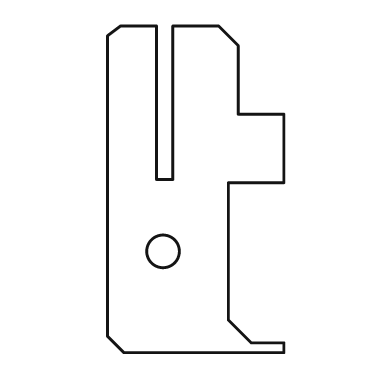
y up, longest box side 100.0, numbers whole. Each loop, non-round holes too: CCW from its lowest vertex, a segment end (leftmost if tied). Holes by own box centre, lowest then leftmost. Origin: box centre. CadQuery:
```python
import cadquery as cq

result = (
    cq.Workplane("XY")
    .moveTo(-22.0, -50.0)
    .lineTo(27.0, -50.0)
    .lineTo(27.0, -47.0)
    .lineTo(17.0, -47.0)
    .lineTo(10.0, -40.0)
    .lineTo(10.0, 2.0)
    .lineTo(27.0, 2.0)
    .lineTo(27.0, 23.0)
    .lineTo(13.0, 23.0)
    .lineTo(13.0, 44.0)
    .lineTo(7.0, 50.0)
    .lineTo(-7.0, 50.0)
    .lineTo(-7.0, 3.0)
    .lineTo(-12.0, 3.0)
    .lineTo(-12.0, 50.0)
    .lineTo(-23.0, 50.0)
    .lineTo(-27.0, 47.0)
    .lineTo(-27.0, -45.0)
    .close()
    .moveTo(-10.0, -19.0)
    .circle(5.0)
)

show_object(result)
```